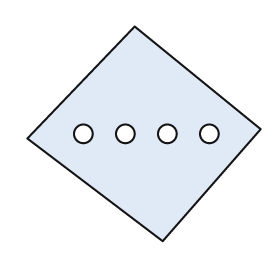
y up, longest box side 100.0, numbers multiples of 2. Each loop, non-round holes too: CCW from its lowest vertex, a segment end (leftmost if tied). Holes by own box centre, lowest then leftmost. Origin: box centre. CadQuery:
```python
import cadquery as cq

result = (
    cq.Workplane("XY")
    .moveTo(8.0, -46.0)
    .lineTo(50.0, 2.0)
    .lineTo(-4.0, 46.0)
    .lineTo(-50.0, -2.0)
    .close()
    .moveTo(-26.0, 0.0)
    .circle(4.0)
    .moveTo(-8.0, 0.0)
    .circle(4.0)
    .moveTo(10.0, 0.0)
    .circle(4.0)
    .moveTo(28.0, 0.0)
    .circle(4.0)
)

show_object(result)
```